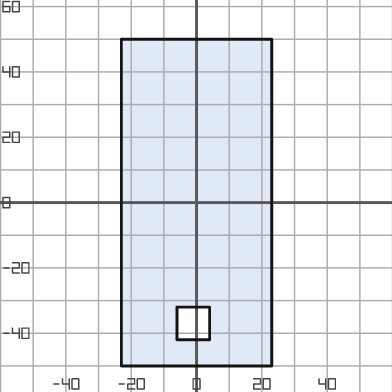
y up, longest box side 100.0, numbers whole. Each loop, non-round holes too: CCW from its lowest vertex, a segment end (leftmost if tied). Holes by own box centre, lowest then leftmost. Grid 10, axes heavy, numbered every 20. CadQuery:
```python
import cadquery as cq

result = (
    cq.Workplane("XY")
    .moveTo(-23.0, -50.0)
    .lineTo(23.0, -50.0)
    .lineTo(23.0, 50.0)
    .lineTo(-23.0, 50.0)
    .close()
    .moveTo(-6.0, -42.0)
    .lineTo(4.0, -42.0)
    .lineTo(4.0, -32.0)
    .lineTo(-6.0, -32.0)
    .close()
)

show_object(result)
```